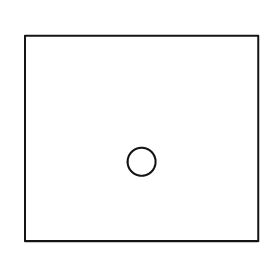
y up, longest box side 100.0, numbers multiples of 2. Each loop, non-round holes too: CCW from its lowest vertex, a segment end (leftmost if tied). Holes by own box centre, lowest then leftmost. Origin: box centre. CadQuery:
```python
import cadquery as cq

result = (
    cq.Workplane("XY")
    .moveTo(-50.0, -44.0)
    .lineTo(50.0, -44.0)
    .lineTo(50.0, 44.0)
    .lineTo(-50.0, 44.0)
    .close()
    .moveTo(0.0, -10.0)
    .circle(6.0)
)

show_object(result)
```